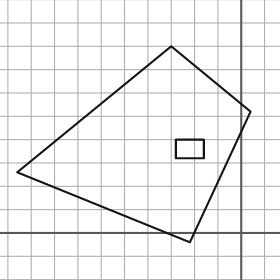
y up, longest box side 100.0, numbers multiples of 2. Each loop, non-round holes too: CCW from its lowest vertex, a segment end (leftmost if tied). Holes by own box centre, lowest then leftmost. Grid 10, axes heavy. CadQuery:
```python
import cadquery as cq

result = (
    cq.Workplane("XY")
    .moveTo(-22.0, -4.0)
    .lineTo(4.0, 52.0)
    .lineTo(-30.0, 80.0)
    .lineTo(-96.0, 26.0)
    .close()
    .moveTo(-28.0, 32.0)
    .lineTo(-16.0, 32.0)
    .lineTo(-16.0, 40.0)
    .lineTo(-28.0, 40.0)
    .close()
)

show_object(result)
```